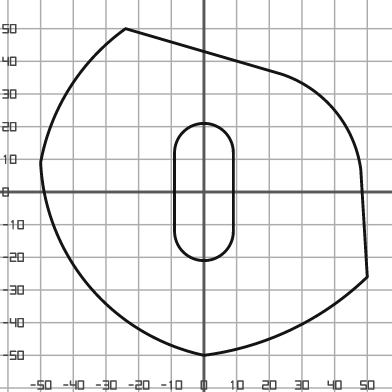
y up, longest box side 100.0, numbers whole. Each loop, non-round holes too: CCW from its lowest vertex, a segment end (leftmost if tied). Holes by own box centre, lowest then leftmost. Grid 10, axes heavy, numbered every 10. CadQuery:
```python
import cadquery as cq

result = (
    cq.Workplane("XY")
    .moveTo(0.0, -50.0)
    .threePointArc((27.0, -42.0), (50.0, -26.0))
    .lineTo(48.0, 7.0)
    .threePointArc((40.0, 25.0), (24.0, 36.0))
    .lineTo(-24.0, 50.0)
    .threePointArc((-41.0, 32.0), (-50.0, 9.0))
    .threePointArc((-35.0, -29.0), (0.0, -50.0))
    .close()
    .moveTo(-9.0, -12.0)
    .threePointArc((0.0, -21.0), (9.0, -12.0))
    .lineTo(9.0, 12.0)
    .threePointArc((0.0, 21.0), (-9.0, 12.0))
    .close()
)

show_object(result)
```